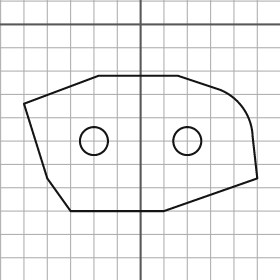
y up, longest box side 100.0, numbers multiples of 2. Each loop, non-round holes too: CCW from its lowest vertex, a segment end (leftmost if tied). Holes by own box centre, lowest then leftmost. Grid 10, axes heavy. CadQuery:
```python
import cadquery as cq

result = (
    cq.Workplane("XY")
    .moveTo(-30.0, -80.0)
    .lineTo(10.0, -80.0)
    .lineTo(50.0, -66.0)
    .lineTo(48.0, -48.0)
    .threePointArc((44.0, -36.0), (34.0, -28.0))
    .lineTo(16.0, -22.0)
    .lineTo(-18.0, -22.0)
    .lineTo(-50.0, -34.0)
    .lineTo(-40.0, -66.0)
    .close()
    .moveTo(-20.0, -50.0)
    .circle(6.0)
    .moveTo(20.0, -50.0)
    .circle(6.0)
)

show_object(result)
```